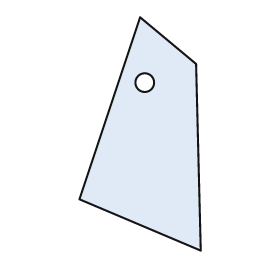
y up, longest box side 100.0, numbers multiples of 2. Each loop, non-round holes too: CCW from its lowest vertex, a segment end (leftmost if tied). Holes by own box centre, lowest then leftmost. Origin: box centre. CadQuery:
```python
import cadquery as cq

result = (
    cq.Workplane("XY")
    .moveTo(26.0, -50.0)
    .lineTo(24.0, 30.0)
    .lineTo(0.0, 50.0)
    .lineTo(-26.0, -28.0)
    .close()
    .moveTo(2.0, 22.0)
    .circle(4.0)
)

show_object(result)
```